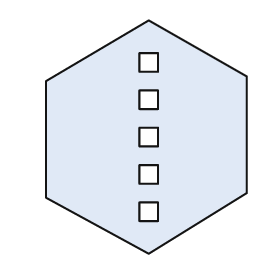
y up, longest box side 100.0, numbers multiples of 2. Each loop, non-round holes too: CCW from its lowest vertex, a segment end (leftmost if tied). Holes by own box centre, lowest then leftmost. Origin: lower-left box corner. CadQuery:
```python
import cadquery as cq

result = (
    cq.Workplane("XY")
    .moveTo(44.0, 0.0)
    .lineTo(86.0, 26.0)
    .lineTo(86.0, 76.0)
    .lineTo(44.0, 100.0)
    .lineTo(0.0, 74.0)
    .lineTo(0.0, 24.0)
    .close()
    .moveTo(40.0, 14.0)
    .lineTo(48.0, 14.0)
    .lineTo(48.0, 22.0)
    .lineTo(40.0, 22.0)
    .close()
    .moveTo(40.0, 30.0)
    .lineTo(48.0, 30.0)
    .lineTo(48.0, 38.0)
    .lineTo(40.0, 38.0)
    .close()
    .moveTo(40.0, 46.0)
    .lineTo(48.0, 46.0)
    .lineTo(48.0, 54.0)
    .lineTo(40.0, 54.0)
    .close()
    .moveTo(40.0, 62.0)
    .lineTo(48.0, 62.0)
    .lineTo(48.0, 70.0)
    .lineTo(40.0, 70.0)
    .close()
    .moveTo(40.0, 78.0)
    .lineTo(48.0, 78.0)
    .lineTo(48.0, 86.0)
    .lineTo(40.0, 86.0)
    .close()
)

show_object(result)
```